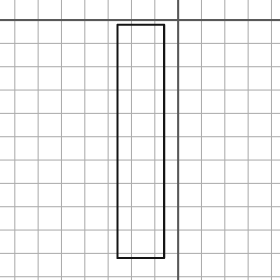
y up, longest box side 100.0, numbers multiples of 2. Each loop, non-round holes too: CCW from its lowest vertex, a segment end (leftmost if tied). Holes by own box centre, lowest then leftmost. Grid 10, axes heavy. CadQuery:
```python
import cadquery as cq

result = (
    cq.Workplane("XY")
    .moveTo(-26.0, -102.0)
    .lineTo(-6.0, -102.0)
    .lineTo(-6.0, -2.0)
    .lineTo(-26.0, -2.0)
    .close()
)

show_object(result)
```